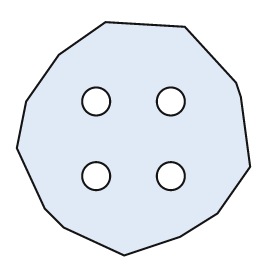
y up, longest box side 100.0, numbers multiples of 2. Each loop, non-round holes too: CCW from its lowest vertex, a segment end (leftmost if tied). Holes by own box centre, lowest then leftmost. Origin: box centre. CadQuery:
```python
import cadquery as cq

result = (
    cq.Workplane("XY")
    .moveTo(-4.0, -50.0)
    .lineTo(20.0, -42.0)
    .lineTo(36.0, -32.0)
    .lineTo(50.0, -12.0)
    .lineTo(46.0, 18.0)
    .lineTo(44.0, 24.0)
    .lineTo(22.0, 48.0)
    .lineTo(-12.0, 50.0)
    .lineTo(-32.0, 36.0)
    .lineTo(-46.0, 16.0)
    .lineTo(-50.0, -4.0)
    .lineTo(-38.0, -30.0)
    .lineTo(-30.0, -38.0)
    .close()
    .moveTo(-16.0, -16.0)
    .circle(6.0)
    .moveTo(16.0, -16.0)
    .circle(6.0)
    .moveTo(-16.0, 16.0)
    .circle(6.0)
    .moveTo(16.0, 16.0)
    .circle(6.0)
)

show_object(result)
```